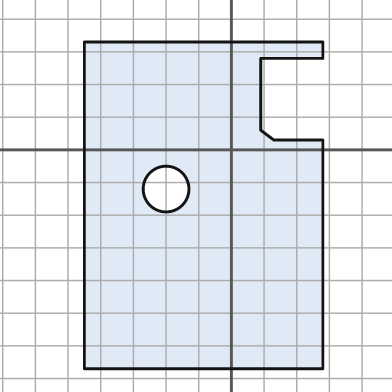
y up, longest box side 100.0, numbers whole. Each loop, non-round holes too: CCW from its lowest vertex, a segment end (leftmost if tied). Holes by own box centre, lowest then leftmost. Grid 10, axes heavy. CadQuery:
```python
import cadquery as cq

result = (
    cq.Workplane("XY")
    .moveTo(-45.0, -67.0)
    .lineTo(28.0, -67.0)
    .lineTo(28.0, 3.0)
    .lineTo(13.0, 3.0)
    .lineTo(9.0, 6.0)
    .lineTo(9.0, 28.0)
    .lineTo(28.0, 28.0)
    .lineTo(28.0, 33.0)
    .lineTo(-45.0, 33.0)
    .close()
    .moveTo(-20.0, -12.0)
    .circle(7.0)
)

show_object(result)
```